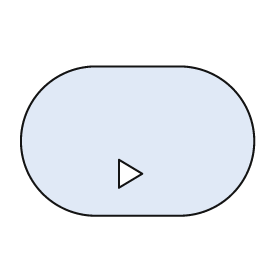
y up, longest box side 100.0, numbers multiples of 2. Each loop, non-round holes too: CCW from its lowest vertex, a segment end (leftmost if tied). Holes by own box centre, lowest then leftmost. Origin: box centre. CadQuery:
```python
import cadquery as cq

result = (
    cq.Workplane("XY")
    .moveTo(-18.0, -32.0)
    .lineTo(18.0, -32.0)
    .threePointArc((50.0, 0.0), (18.0, 32.0))
    .lineTo(-18.0, 32.0)
    .threePointArc((-50.0, 0.0), (-18.0, -32.0))
    .close()
    .moveTo(-8.0, -20.0)
    .lineTo(2.0, -14.0)
    .lineTo(-8.0, -8.0)
    .close()
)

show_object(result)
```